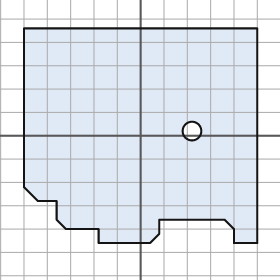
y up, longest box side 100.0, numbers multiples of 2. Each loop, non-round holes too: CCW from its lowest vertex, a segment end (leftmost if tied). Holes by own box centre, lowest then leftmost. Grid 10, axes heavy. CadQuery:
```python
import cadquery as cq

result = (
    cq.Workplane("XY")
    .moveTo(-18.0, -46.0)
    .lineTo(4.0, -46.0)
    .lineTo(8.0, -42.0)
    .lineTo(8.0, -36.0)
    .lineTo(36.0, -36.0)
    .lineTo(40.0, -40.0)
    .lineTo(40.0, -46.0)
    .lineTo(50.0, -46.0)
    .lineTo(50.0, 46.0)
    .lineTo(-50.0, 46.0)
    .lineTo(-50.0, -22.0)
    .lineTo(-44.0, -28.0)
    .lineTo(-36.0, -28.0)
    .lineTo(-36.0, -36.0)
    .lineTo(-32.0, -40.0)
    .lineTo(-18.0, -40.0)
    .close()
    .moveTo(22.0, 2.0)
    .circle(4.0)
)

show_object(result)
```